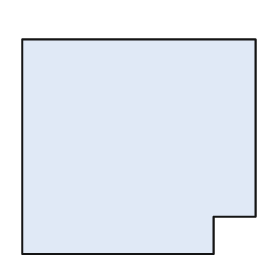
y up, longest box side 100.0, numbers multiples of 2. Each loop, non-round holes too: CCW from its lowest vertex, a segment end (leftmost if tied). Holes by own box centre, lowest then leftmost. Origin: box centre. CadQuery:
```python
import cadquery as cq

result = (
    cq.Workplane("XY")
    .moveTo(-50.0, -46.0)
    .lineTo(32.0, -46.0)
    .lineTo(32.0, -30.0)
    .lineTo(50.0, -30.0)
    .lineTo(50.0, 46.0)
    .lineTo(-50.0, 46.0)
    .close()
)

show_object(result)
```